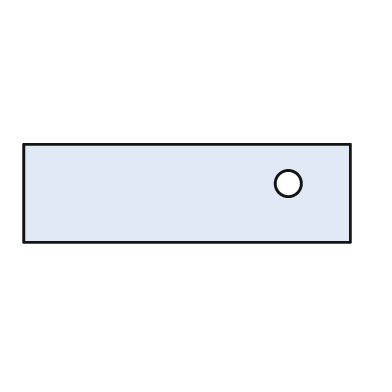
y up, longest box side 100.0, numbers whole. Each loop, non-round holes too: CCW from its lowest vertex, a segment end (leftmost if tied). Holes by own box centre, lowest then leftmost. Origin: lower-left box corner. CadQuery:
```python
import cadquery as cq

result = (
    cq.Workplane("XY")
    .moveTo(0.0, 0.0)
    .lineTo(100.0, 0.0)
    .lineTo(100.0, 30.0)
    .lineTo(0.0, 30.0)
    .close()
    .moveTo(81.0, 18.0)
    .circle(4.0)
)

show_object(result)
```